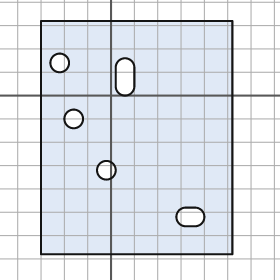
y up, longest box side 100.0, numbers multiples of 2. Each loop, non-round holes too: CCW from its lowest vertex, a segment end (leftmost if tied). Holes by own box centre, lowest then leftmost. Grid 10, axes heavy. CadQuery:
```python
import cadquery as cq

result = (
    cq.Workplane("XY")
    .moveTo(-30.0, -68.0)
    .lineTo(52.0, -68.0)
    .lineTo(52.0, 32.0)
    .lineTo(-30.0, 32.0)
    .close()
    .moveTo(32.0, -56.0)
    .lineTo(36.0, -56.0)
    .threePointArc((40.0, -52.0), (36.0, -48.0))
    .lineTo(32.0, -48.0)
    .threePointArc((28.0, -52.0), (32.0, -56.0))
    .close()
    .moveTo(-2.0, -32.0)
    .circle(4.0)
    .moveTo(-16.0, -10.0)
    .circle(4.0)
    .moveTo(2.0, 4.0)
    .threePointArc((6.0, 0.0), (10.0, 4.0))
    .lineTo(10.0, 12.0)
    .threePointArc((6.0, 16.0), (2.0, 12.0))
    .close()
    .moveTo(-22.0, 14.0)
    .circle(4.0)
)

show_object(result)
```